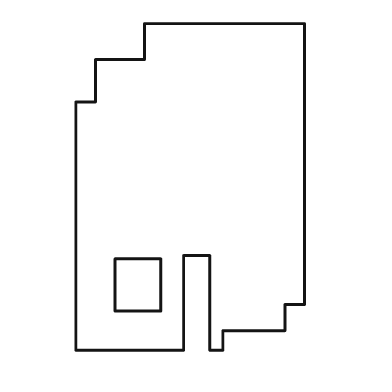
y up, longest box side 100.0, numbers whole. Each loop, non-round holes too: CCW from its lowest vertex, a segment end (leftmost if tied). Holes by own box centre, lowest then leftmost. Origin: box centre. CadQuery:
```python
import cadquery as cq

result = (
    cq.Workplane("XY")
    .moveTo(-35.0, -50.0)
    .lineTo(-2.0, -50.0)
    .lineTo(-2.0, -21.0)
    .lineTo(6.0, -21.0)
    .lineTo(6.0, -50.0)
    .lineTo(10.0, -50.0)
    .lineTo(10.0, -44.0)
    .lineTo(29.0, -44.0)
    .lineTo(29.0, -36.0)
    .lineTo(35.0, -36.0)
    .lineTo(35.0, 50.0)
    .lineTo(-14.0, 50.0)
    .lineTo(-14.0, 39.0)
    .lineTo(-29.0, 39.0)
    .lineTo(-29.0, 26.0)
    .lineTo(-35.0, 26.0)
    .close()
    .moveTo(-23.0, -38.0)
    .lineTo(-9.0, -38.0)
    .lineTo(-9.0, -22.0)
    .lineTo(-23.0, -22.0)
    .close()
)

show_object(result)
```